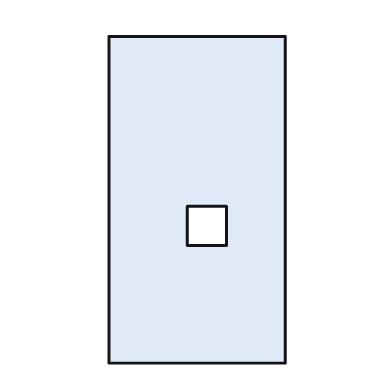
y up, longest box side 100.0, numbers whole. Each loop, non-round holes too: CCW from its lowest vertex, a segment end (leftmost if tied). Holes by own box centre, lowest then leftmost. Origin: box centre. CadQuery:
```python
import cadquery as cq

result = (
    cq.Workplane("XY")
    .moveTo(-27.0, -50.0)
    .lineTo(27.0, -50.0)
    .lineTo(27.0, 50.0)
    .lineTo(-27.0, 50.0)
    .close()
    .moveTo(-3.0, -14.0)
    .lineTo(9.0, -14.0)
    .lineTo(9.0, -2.0)
    .lineTo(-3.0, -2.0)
    .close()
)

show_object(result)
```